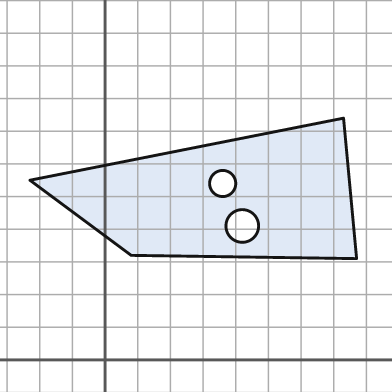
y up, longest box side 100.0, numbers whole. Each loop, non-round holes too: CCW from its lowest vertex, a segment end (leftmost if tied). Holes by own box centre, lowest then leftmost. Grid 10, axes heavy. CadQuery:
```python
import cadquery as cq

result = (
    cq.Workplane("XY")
    .moveTo(77.0, 31.0)
    .lineTo(73.0, 74.0)
    .lineTo(-23.0, 55.0)
    .lineTo(8.0, 32.0)
    .close()
    .moveTo(42.0, 41.0)
    .circle(5.0)
    .moveTo(36.0, 54.0)
    .circle(4.0)
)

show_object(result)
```